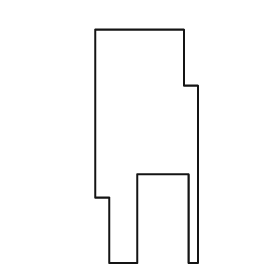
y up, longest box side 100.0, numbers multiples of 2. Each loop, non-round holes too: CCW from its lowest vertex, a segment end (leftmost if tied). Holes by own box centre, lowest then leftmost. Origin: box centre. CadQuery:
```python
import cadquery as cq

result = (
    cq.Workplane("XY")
    .moveTo(-16.0, -50.0)
    .lineTo(-4.0, -50.0)
    .lineTo(-4.0, -12.0)
    .lineTo(18.0, -12.0)
    .lineTo(18.0, -50.0)
    .lineTo(22.0, -50.0)
    .lineTo(22.0, 26.0)
    .lineTo(16.0, 26.0)
    .lineTo(16.0, 50.0)
    .lineTo(-22.0, 50.0)
    .lineTo(-22.0, -22.0)
    .lineTo(-16.0, -22.0)
    .close()
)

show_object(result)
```